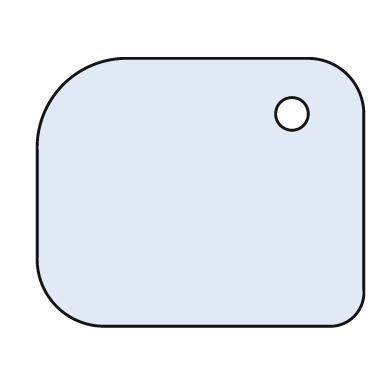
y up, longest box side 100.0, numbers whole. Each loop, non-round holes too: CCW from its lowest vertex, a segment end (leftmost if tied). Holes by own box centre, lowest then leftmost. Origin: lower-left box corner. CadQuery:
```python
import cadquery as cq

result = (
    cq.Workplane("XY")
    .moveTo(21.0, 0.0)
    .lineTo(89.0, 0.0)
    .threePointArc((97.0, 3.0), (100.0, 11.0))
    .lineTo(100.0, 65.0)
    .threePointArc((95.0, 77.0), (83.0, 82.0))
    .lineTo(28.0, 82.0)
    .threePointArc((8.0, 74.0), (0.0, 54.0))
    .lineTo(0.0, 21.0)
    .threePointArc((6.0, 6.0), (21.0, 0.0))
    .close()
    .moveTo(78.0, 65.0)
    .circle(5.0)
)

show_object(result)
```